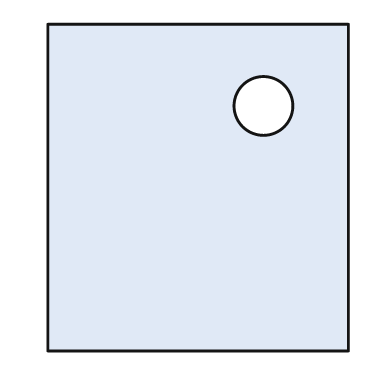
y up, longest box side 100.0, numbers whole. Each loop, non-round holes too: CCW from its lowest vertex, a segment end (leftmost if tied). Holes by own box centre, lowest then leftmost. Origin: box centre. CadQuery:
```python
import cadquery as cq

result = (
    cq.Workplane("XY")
    .moveTo(-46.0, -50.0)
    .lineTo(46.0, -50.0)
    .lineTo(46.0, 50.0)
    .lineTo(-46.0, 50.0)
    .close()
    .moveTo(20.0, 25.0)
    .circle(9.0)
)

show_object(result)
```